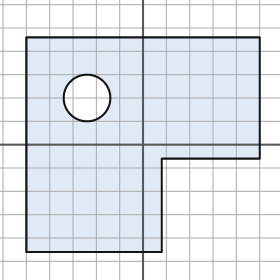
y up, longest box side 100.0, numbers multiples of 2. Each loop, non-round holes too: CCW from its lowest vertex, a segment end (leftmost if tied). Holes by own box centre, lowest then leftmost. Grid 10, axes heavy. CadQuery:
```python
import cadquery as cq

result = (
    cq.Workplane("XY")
    .moveTo(-50.0, -46.0)
    .lineTo(8.0, -46.0)
    .lineTo(8.0, -6.0)
    .lineTo(50.0, -6.0)
    .lineTo(50.0, 46.0)
    .lineTo(-50.0, 46.0)
    .close()
    .moveTo(-24.0, 20.0)
    .circle(10.0)
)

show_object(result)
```